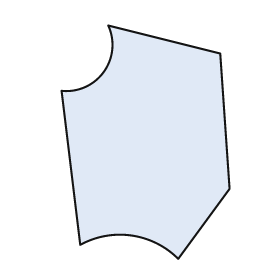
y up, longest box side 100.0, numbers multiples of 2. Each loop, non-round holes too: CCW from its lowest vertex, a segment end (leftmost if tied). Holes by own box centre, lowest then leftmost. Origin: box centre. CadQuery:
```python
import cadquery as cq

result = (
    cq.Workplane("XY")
    .moveTo(14.0, -50.0)
    .lineTo(36.0, -20.0)
    .lineTo(32.0, 38.0)
    .lineTo(-16.0, 50.0)
    .threePointArc((-18.0, 30.0), (-36.0, 22.0))
    .lineTo(-28.0, -44.0)
    .threePointArc((-6.0, -40.0), (14.0, -50.0))
    .close()
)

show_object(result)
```